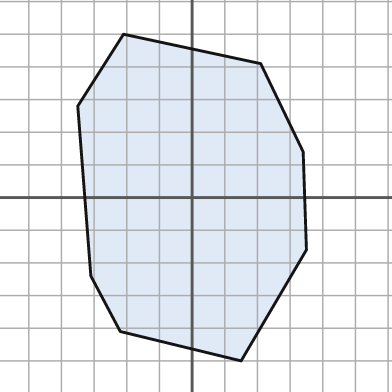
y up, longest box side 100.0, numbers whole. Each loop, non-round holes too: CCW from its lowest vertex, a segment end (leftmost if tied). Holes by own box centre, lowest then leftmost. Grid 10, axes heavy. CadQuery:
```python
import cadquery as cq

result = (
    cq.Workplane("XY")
    .moveTo(15.0, -50.0)
    .lineTo(35.0, -16.0)
    .lineTo(34.0, 14.0)
    .lineTo(21.0, 41.0)
    .lineTo(-21.0, 50.0)
    .lineTo(-35.0, 28.0)
    .lineTo(-31.0, -24.0)
    .lineTo(-22.0, -41.0)
    .close()
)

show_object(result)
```